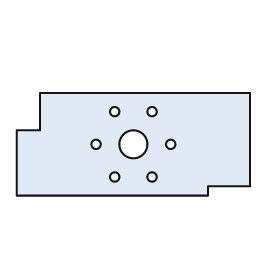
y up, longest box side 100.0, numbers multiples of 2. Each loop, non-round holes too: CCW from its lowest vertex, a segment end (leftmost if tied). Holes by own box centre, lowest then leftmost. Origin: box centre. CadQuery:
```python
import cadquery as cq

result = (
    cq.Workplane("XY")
    .moveTo(-50.0, -22.0)
    .lineTo(32.0, -22.0)
    .lineTo(32.0, -18.0)
    .lineTo(50.0, -18.0)
    .lineTo(50.0, 22.0)
    .lineTo(-40.0, 22.0)
    .lineTo(-40.0, 6.0)
    .lineTo(-50.0, 6.0)
    .close()
    .moveTo(-8.0, -14.0)
    .circle(2.0)
    .moveTo(8.0, -14.0)
    .circle(2.0)
    .moveTo(-16.0, 0.0)
    .circle(2.0)
    .moveTo(0.0, 0.0)
    .circle(6.0)
    .moveTo(16.0, 0.0)
    .circle(2.0)
    .moveTo(-8.0, 14.0)
    .circle(2.0)
    .moveTo(8.0, 14.0)
    .circle(2.0)
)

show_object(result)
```